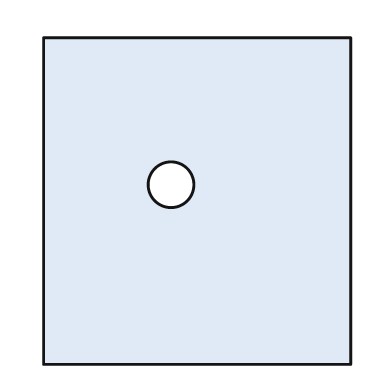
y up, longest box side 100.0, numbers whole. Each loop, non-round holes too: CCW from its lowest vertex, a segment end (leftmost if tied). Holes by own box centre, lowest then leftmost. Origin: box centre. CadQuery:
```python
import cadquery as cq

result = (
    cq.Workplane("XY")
    .moveTo(-47.0, -50.0)
    .lineTo(47.0, -50.0)
    .lineTo(47.0, 50.0)
    .lineTo(-47.0, 50.0)
    .close()
    .moveTo(-8.0, 5.0)
    .circle(7.0)
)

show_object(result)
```